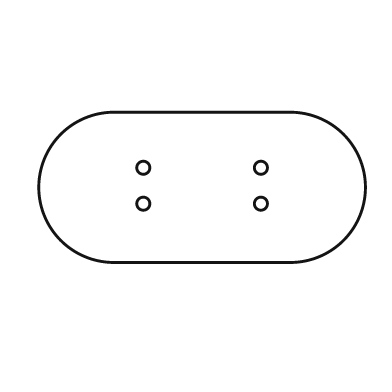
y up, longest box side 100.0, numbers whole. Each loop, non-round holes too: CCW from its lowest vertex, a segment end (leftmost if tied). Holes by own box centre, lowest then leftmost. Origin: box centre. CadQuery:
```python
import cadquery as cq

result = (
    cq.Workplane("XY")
    .moveTo(-27.0, -23.0)
    .lineTo(27.0, -23.0)
    .threePointArc((50.0, 0.0), (27.0, 23.0))
    .lineTo(-27.0, 23.0)
    .threePointArc((-50.0, 0.0), (-27.0, -23.0))
    .close()
    .moveTo(-18.0, -5.0)
    .circle(2.0)
    .moveTo(18.0, -5.0)
    .circle(2.0)
    .moveTo(-18.0, 6.0)
    .circle(2.0)
    .moveTo(18.0, 6.0)
    .circle(2.0)
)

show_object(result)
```